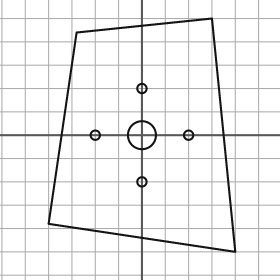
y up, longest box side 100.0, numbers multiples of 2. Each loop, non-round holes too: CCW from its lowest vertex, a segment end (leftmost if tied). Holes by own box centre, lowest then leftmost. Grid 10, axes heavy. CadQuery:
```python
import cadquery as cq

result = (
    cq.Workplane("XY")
    .moveTo(40.0, -50.0)
    .lineTo(30.0, 50.0)
    .lineTo(-28.0, 44.0)
    .lineTo(-40.0, -38.0)
    .close()
    .moveTo(0.0, -20.0)
    .circle(2.0)
    .moveTo(-20.0, 0.0)
    .circle(2.0)
    .moveTo(0.0, 0.0)
    .circle(6.0)
    .moveTo(20.0, 0.0)
    .circle(2.0)
    .moveTo(0.0, 20.0)
    .circle(2.0)
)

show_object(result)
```